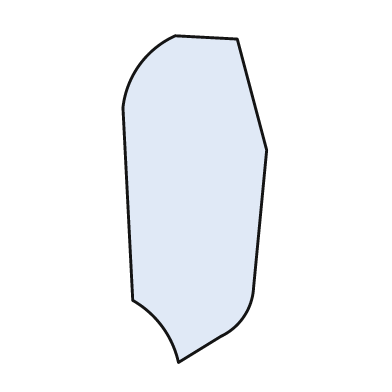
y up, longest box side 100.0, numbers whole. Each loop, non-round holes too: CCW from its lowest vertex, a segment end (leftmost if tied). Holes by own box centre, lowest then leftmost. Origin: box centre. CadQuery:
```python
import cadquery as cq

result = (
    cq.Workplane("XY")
    .moveTo(-5.0, -50.0)
    .lineTo(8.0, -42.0)
    .threePointArc((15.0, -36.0), (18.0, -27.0))
    .lineTo(22.0, 15.0)
    .lineTo(13.0, 49.0)
    .lineTo(-6.0, 50.0)
    .threePointArc((-17.0, 41.0), (-22.0, 28.0))
    .lineTo(-19.0, -31.0)
    .threePointArc((-10.0, -39.0), (-5.0, -50.0))
    .close()
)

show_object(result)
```